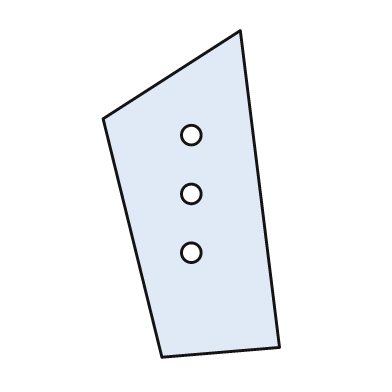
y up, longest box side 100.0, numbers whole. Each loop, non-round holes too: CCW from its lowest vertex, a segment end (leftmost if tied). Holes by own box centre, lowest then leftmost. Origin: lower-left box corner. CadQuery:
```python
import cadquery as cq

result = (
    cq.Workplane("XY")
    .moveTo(18.0, 0.0)
    .lineTo(54.0, 3.0)
    .lineTo(42.0, 100.0)
    .lineTo(0.0, 73.0)
    .close()
    .moveTo(27.0, 32.0)
    .circle(3.0)
    .moveTo(27.0, 50.0)
    .circle(3.0)
    .moveTo(27.0, 68.0)
    .circle(3.0)
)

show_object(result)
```